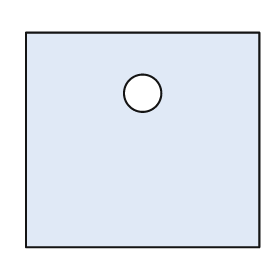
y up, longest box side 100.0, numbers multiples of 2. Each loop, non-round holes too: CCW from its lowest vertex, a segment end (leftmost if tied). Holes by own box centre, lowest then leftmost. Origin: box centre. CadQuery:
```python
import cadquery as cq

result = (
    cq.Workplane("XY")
    .moveTo(-50.0, -46.0)
    .lineTo(50.0, -46.0)
    .lineTo(50.0, 46.0)
    .lineTo(-50.0, 46.0)
    .close()
    .moveTo(0.0, 20.0)
    .circle(8.0)
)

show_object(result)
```